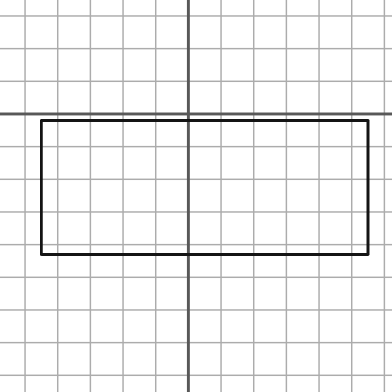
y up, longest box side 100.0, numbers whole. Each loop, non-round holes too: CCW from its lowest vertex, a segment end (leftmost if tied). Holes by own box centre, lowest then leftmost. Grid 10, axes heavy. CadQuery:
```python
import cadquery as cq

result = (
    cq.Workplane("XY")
    .moveTo(-45.0, -43.0)
    .lineTo(55.0, -43.0)
    .lineTo(55.0, -2.0)
    .lineTo(-45.0, -2.0)
    .close()
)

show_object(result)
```